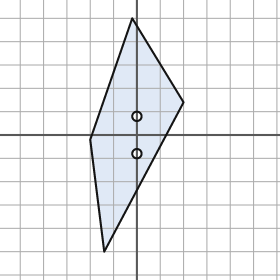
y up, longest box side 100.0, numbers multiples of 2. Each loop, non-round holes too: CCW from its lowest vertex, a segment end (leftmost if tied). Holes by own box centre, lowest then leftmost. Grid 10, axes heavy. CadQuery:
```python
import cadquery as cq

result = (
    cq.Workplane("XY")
    .moveTo(-14.0, -50.0)
    .lineTo(20.0, 14.0)
    .lineTo(-2.0, 50.0)
    .lineTo(-20.0, -2.0)
    .close()
    .moveTo(0.0, -8.0)
    .circle(2.0)
    .moveTo(0.0, 8.0)
    .circle(2.0)
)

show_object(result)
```